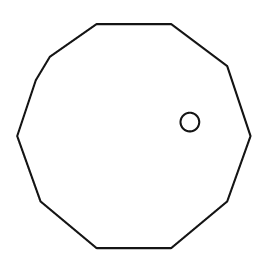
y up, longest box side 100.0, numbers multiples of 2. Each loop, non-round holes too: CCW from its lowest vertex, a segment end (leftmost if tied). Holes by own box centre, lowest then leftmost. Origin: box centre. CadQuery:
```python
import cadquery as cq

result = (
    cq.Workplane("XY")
    .moveTo(-16.0, -48.0)
    .lineTo(16.0, -48.0)
    .lineTo(40.0, -28.0)
    .lineTo(50.0, 0.0)
    .lineTo(40.0, 30.0)
    .lineTo(16.0, 48.0)
    .lineTo(-16.0, 48.0)
    .lineTo(-36.0, 34.0)
    .lineTo(-42.0, 24.0)
    .lineTo(-50.0, 0.0)
    .lineTo(-40.0, -28.0)
    .close()
    .moveTo(24.0, 6.0)
    .circle(4.0)
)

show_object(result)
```